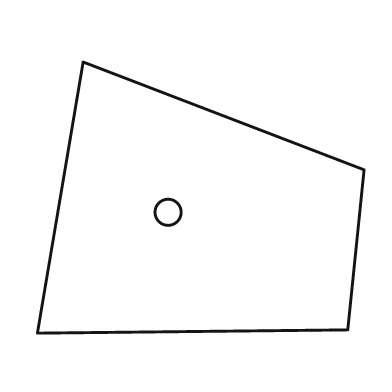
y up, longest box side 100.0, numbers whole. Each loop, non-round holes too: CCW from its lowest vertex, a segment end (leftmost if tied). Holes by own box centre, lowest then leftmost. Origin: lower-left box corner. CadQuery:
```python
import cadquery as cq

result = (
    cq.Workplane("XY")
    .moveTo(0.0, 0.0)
    .lineTo(95.0, 1.0)
    .lineTo(100.0, 50.0)
    .lineTo(14.0, 83.0)
    .close()
    .moveTo(40.0, 37.0)
    .circle(4.0)
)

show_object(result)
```